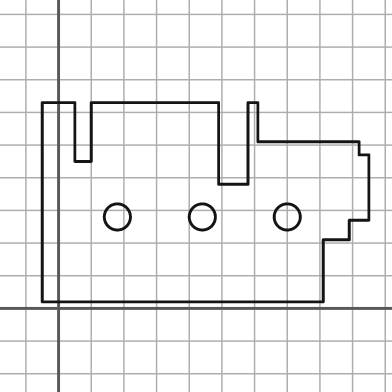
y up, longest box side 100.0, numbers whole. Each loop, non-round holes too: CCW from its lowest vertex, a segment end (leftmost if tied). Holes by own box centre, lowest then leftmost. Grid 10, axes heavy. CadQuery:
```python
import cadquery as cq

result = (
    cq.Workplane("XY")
    .moveTo(-5.0, 2.0)
    .lineTo(81.0, 2.0)
    .lineTo(81.0, 21.0)
    .lineTo(89.0, 21.0)
    .lineTo(89.0, 27.0)
    .lineTo(95.0, 27.0)
    .lineTo(95.0, 47.0)
    .lineTo(92.0, 47.0)
    .lineTo(92.0, 51.0)
    .lineTo(61.0, 51.0)
    .lineTo(61.0, 63.0)
    .lineTo(58.0, 63.0)
    .lineTo(58.0, 38.0)
    .lineTo(49.0, 38.0)
    .lineTo(49.0, 63.0)
    .lineTo(10.0, 63.0)
    .lineTo(10.0, 45.0)
    .lineTo(5.0, 45.0)
    .lineTo(5.0, 63.0)
    .lineTo(-5.0, 63.0)
    .close()
    .moveTo(18.0, 28.0)
    .circle(4.0)
    .moveTo(44.0, 28.0)
    .circle(4.0)
    .moveTo(70.0, 28.0)
    .circle(4.0)
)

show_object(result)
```